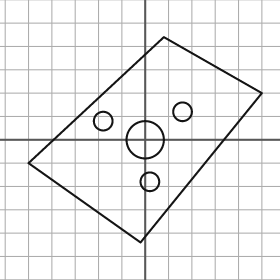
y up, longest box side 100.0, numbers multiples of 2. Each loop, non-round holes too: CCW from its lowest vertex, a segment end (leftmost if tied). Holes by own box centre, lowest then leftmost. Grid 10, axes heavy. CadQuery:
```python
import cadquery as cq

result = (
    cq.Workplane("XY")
    .moveTo(-2.0, -44.0)
    .lineTo(50.0, 20.0)
    .lineTo(8.0, 44.0)
    .lineTo(-50.0, -10.0)
    .close()
    .moveTo(2.0, -18.0)
    .circle(4.0)
    .moveTo(0.0, 0.0)
    .circle(8.0)
    .moveTo(-18.0, 8.0)
    .circle(4.0)
    .moveTo(16.0, 12.0)
    .circle(4.0)
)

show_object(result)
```